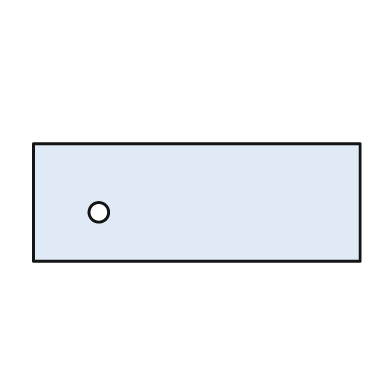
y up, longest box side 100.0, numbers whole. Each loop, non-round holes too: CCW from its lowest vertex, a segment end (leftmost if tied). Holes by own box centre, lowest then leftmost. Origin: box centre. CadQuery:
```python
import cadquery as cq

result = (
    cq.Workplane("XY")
    .moveTo(-50.0, -18.0)
    .lineTo(50.0, -18.0)
    .lineTo(50.0, 18.0)
    .lineTo(-50.0, 18.0)
    .close()
    .moveTo(-30.0, -3.0)
    .circle(3.0)
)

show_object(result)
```